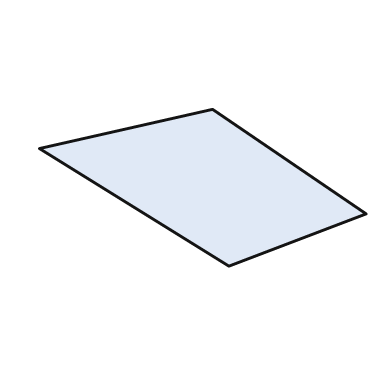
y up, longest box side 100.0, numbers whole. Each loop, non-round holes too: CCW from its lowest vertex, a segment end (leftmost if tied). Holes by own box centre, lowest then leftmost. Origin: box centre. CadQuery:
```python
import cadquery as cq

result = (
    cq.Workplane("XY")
    .moveTo(8.0, -24.0)
    .lineTo(50.0, -8.0)
    .lineTo(3.0, 24.0)
    .lineTo(-50.0, 12.0)
    .close()
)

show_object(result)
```